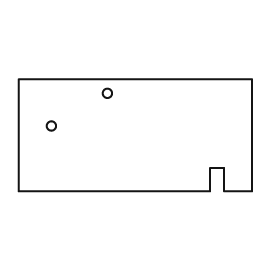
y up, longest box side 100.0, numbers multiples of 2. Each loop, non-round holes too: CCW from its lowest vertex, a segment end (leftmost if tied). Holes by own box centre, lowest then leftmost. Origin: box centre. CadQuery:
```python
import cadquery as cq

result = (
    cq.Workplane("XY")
    .moveTo(-50.0, -24.0)
    .lineTo(32.0, -24.0)
    .lineTo(32.0, -14.0)
    .lineTo(38.0, -14.0)
    .lineTo(38.0, -24.0)
    .lineTo(50.0, -24.0)
    .lineTo(50.0, 24.0)
    .lineTo(-50.0, 24.0)
    .close()
    .moveTo(-36.0, 4.0)
    .circle(2.0)
    .moveTo(-12.0, 18.0)
    .circle(2.0)
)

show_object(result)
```